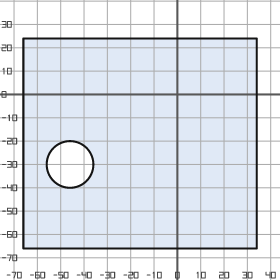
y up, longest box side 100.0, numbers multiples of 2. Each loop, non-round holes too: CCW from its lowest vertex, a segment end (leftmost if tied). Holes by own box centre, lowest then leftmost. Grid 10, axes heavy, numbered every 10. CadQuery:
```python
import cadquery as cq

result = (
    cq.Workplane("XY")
    .moveTo(-66.0, -66.0)
    .lineTo(34.0, -66.0)
    .lineTo(34.0, 24.0)
    .lineTo(-66.0, 24.0)
    .close()
    .moveTo(-46.0, -30.0)
    .circle(10.0)
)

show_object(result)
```